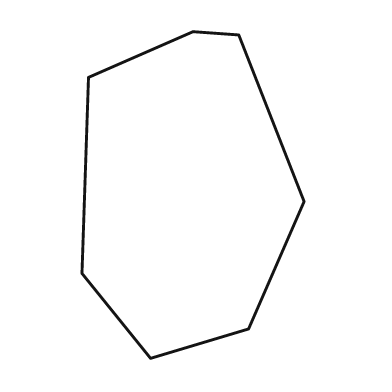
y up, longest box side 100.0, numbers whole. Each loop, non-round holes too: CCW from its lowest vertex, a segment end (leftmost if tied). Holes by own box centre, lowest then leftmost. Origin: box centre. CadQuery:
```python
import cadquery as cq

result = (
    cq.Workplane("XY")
    .moveTo(-13.0, -50.0)
    .lineTo(17.0, -41.0)
    .lineTo(34.0, -2.0)
    .lineTo(14.0, 49.0)
    .lineTo(0.0, 50.0)
    .lineTo(-32.0, 36.0)
    .lineTo(-34.0, -24.0)
    .close()
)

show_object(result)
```